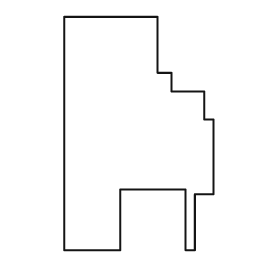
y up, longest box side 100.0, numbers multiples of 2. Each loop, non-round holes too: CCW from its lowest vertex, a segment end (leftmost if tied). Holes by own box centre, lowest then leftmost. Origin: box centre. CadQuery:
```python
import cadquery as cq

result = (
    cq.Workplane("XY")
    .moveTo(-32.0, -50.0)
    .lineTo(-8.0, -50.0)
    .lineTo(-8.0, -24.0)
    .lineTo(20.0, -24.0)
    .lineTo(20.0, -50.0)
    .lineTo(24.0, -50.0)
    .lineTo(24.0, -26.0)
    .lineTo(32.0, -26.0)
    .lineTo(32.0, 6.0)
    .lineTo(28.0, 6.0)
    .lineTo(28.0, 18.0)
    .lineTo(14.0, 18.0)
    .lineTo(14.0, 26.0)
    .lineTo(8.0, 26.0)
    .lineTo(8.0, 50.0)
    .lineTo(-32.0, 50.0)
    .close()
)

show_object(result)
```